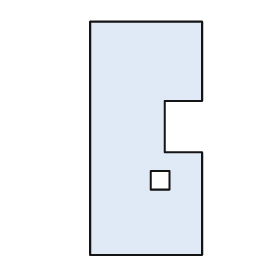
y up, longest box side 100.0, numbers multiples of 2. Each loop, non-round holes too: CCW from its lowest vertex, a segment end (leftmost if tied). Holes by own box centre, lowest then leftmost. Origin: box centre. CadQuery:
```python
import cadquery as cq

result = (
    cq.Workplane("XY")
    .moveTo(-24.0, -50.0)
    .lineTo(24.0, -50.0)
    .lineTo(24.0, -6.0)
    .lineTo(8.0, -6.0)
    .lineTo(8.0, 16.0)
    .lineTo(24.0, 16.0)
    .lineTo(24.0, 50.0)
    .lineTo(-24.0, 50.0)
    .close()
    .moveTo(2.0, -22.0)
    .lineTo(10.0, -22.0)
    .lineTo(10.0, -14.0)
    .lineTo(2.0, -14.0)
    .close()
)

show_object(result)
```